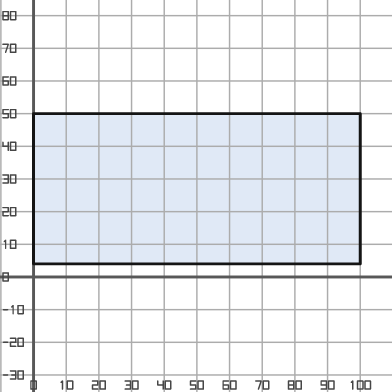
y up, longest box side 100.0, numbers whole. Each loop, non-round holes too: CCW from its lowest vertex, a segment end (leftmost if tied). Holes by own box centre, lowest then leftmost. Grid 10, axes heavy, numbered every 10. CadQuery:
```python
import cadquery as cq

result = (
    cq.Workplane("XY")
    .moveTo(0.0, 4.0)
    .lineTo(100.0, 4.0)
    .lineTo(100.0, 50.0)
    .lineTo(0.0, 50.0)
    .close()
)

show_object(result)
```